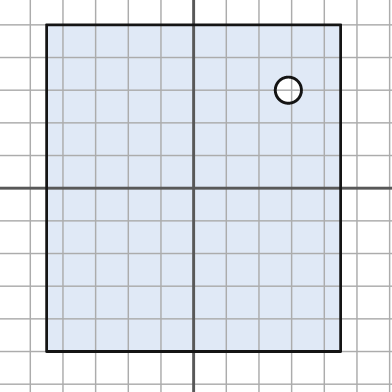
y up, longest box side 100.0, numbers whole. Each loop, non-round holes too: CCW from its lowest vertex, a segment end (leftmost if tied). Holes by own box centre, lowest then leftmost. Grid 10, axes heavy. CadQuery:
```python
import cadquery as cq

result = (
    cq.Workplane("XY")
    .moveTo(-45.0, -50.0)
    .lineTo(45.0, -50.0)
    .lineTo(45.0, 50.0)
    .lineTo(-45.0, 50.0)
    .close()
    .moveTo(29.0, 30.0)
    .circle(4.0)
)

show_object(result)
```